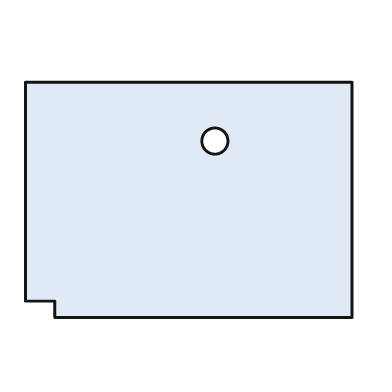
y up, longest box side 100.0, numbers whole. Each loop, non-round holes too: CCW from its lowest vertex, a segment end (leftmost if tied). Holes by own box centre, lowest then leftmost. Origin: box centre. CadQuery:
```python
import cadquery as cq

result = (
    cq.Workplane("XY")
    .moveTo(-41.0, -36.0)
    .lineTo(50.0, -36.0)
    .lineTo(50.0, 36.0)
    .lineTo(-50.0, 36.0)
    .lineTo(-50.0, -31.0)
    .lineTo(-41.0, -31.0)
    .close()
    .moveTo(8.0, 18.0)
    .circle(4.0)
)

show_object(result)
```